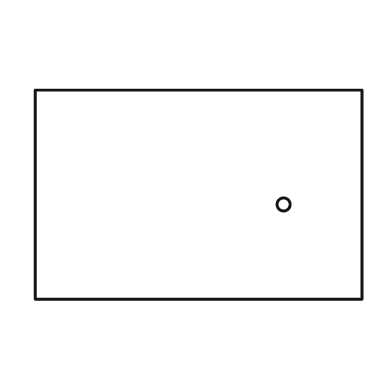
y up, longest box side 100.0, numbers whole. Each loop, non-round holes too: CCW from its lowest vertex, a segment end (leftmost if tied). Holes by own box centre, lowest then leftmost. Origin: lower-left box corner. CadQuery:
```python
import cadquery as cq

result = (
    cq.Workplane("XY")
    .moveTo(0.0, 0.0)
    .lineTo(100.0, 0.0)
    .lineTo(100.0, 64.0)
    .lineTo(0.0, 64.0)
    .close()
    .moveTo(76.0, 29.0)
    .circle(2.0)
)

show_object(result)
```